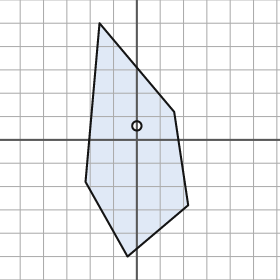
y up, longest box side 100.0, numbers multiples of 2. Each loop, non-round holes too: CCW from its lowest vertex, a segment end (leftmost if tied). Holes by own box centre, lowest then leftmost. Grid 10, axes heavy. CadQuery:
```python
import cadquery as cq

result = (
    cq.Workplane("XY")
    .moveTo(-4.0, -50.0)
    .lineTo(22.0, -28.0)
    .lineTo(16.0, 12.0)
    .lineTo(-16.0, 50.0)
    .lineTo(-22.0, -18.0)
    .close()
    .moveTo(0.0, 6.0)
    .circle(2.0)
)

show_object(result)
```